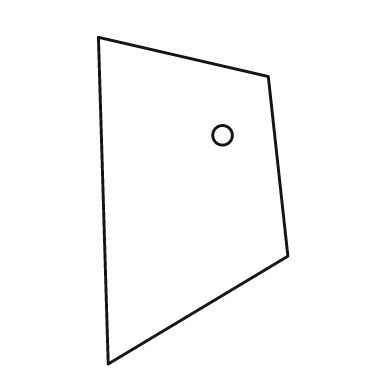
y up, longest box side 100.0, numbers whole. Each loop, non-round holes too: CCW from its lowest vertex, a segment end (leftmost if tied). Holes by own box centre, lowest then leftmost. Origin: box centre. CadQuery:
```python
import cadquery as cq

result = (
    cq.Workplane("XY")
    .moveTo(-26.0, -50.0)
    .lineTo(29.0, -17.0)
    .lineTo(23.0, 38.0)
    .lineTo(-29.0, 50.0)
    .close()
    .moveTo(9.0, 20.0)
    .circle(3.0)
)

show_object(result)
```